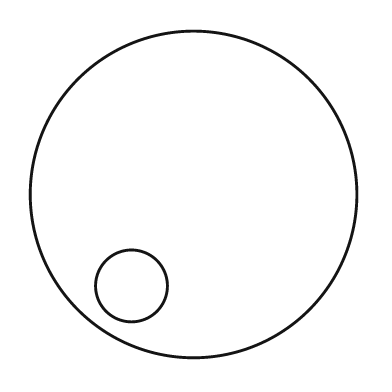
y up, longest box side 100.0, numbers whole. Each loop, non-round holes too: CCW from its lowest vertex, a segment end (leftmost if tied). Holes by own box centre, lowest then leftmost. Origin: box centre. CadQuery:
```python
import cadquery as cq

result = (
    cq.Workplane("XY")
    .moveTo(0.0, 0.0)
    .circle(50.0)
    .moveTo(-19.0, -28.0)
    .circle(11.0)
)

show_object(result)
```